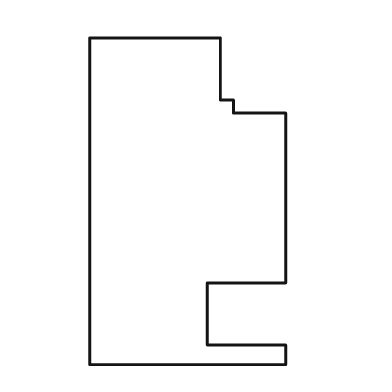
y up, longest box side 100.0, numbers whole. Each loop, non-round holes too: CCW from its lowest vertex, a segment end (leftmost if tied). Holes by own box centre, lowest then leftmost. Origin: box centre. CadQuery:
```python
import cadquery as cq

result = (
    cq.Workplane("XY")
    .moveTo(-30.0, -50.0)
    .lineTo(30.0, -50.0)
    .lineTo(30.0, -44.0)
    .lineTo(6.0, -44.0)
    .lineTo(6.0, -25.0)
    .lineTo(30.0, -25.0)
    .lineTo(30.0, 27.0)
    .lineTo(14.0, 27.0)
    .lineTo(14.0, 31.0)
    .lineTo(10.0, 31.0)
    .lineTo(10.0, 50.0)
    .lineTo(-30.0, 50.0)
    .close()
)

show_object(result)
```